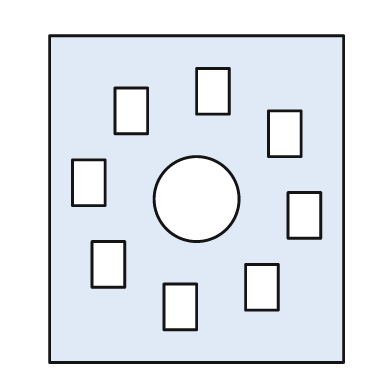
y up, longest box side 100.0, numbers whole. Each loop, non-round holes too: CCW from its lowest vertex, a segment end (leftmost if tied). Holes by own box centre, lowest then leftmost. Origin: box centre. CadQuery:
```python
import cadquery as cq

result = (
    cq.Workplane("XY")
    .moveTo(-45.0, -50.0)
    .lineTo(45.0, -50.0)
    .lineTo(45.0, 50.0)
    .lineTo(-45.0, 50.0)
    .close()
    .moveTo(-10.0, -40.0)
    .lineTo(0.0, -40.0)
    .lineTo(0.0, -26.0)
    .lineTo(-10.0, -26.0)
    .close()
    .moveTo(15.0, -34.0)
    .lineTo(25.0, -34.0)
    .lineTo(25.0, -20.0)
    .lineTo(15.0, -20.0)
    .close()
    .moveTo(-32.0, -27.0)
    .lineTo(-22.0, -27.0)
    .lineTo(-22.0, -13.0)
    .lineTo(-32.0, -13.0)
    .close()
    .moveTo(28.0, -12.0)
    .lineTo(38.0, -12.0)
    .lineTo(38.0, 2.0)
    .lineTo(28.0, 2.0)
    .close()
    .moveTo(0.0, 0.0)
    .circle(13.0)
    .moveTo(-38.0, -2.0)
    .lineTo(-28.0, -2.0)
    .lineTo(-28.0, 12.0)
    .lineTo(-38.0, 12.0)
    .close()
    .moveTo(22.0, 13.0)
    .lineTo(32.0, 13.0)
    .lineTo(32.0, 27.0)
    .lineTo(22.0, 27.0)
    .close()
    .moveTo(-25.0, 20.0)
    .lineTo(-15.0, 20.0)
    .lineTo(-15.0, 34.0)
    .lineTo(-25.0, 34.0)
    .close()
    .moveTo(0.0, 26.0)
    .lineTo(10.0, 26.0)
    .lineTo(10.0, 40.0)
    .lineTo(0.0, 40.0)
    .close()
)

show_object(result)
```